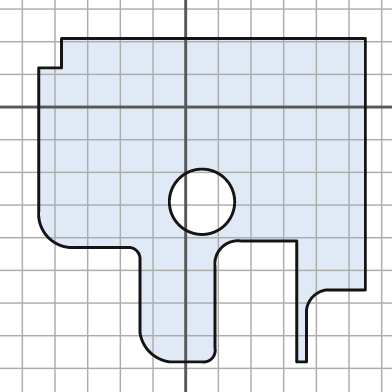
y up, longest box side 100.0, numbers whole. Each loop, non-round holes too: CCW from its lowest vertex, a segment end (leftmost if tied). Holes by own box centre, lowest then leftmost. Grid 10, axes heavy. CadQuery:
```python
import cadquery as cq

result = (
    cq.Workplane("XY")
    .moveTo(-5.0, -78.0)
    .lineTo(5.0, -78.0)
    .threePointArc((8.0, -77.0), (9.0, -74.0))
    .lineTo(9.0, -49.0)
    .threePointArc((11.0, -43.0), (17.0, -41.0))
    .lineTo(34.0, -41.0)
    .lineTo(34.0, -78.0)
    .lineTo(37.0, -78.0)
    .lineTo(37.0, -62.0)
    .threePointArc((39.0, -58.0), (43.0, -56.0))
    .lineTo(55.0, -56.0)
    .lineTo(55.0, 21.0)
    .lineTo(-38.0, 21.0)
    .lineTo(-38.0, 12.0)
    .lineTo(-45.0, 12.0)
    .lineTo(-45.0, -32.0)
    .threePointArc((-42.0, -40.0), (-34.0, -43.0))
    .lineTo(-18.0, -43.0)
    .threePointArc((-15.0, -44.0), (-14.0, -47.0))
    .lineTo(-14.0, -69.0)
    .threePointArc((-11.0, -75.0), (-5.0, -78.0))
    .close()
    .moveTo(5.0, -29.0)
    .circle(10.0)
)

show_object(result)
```